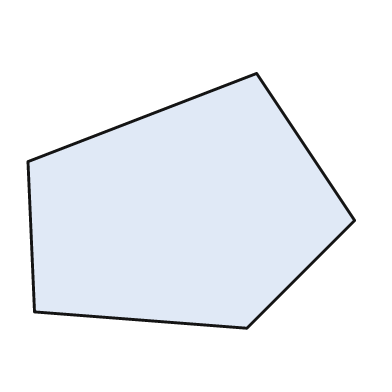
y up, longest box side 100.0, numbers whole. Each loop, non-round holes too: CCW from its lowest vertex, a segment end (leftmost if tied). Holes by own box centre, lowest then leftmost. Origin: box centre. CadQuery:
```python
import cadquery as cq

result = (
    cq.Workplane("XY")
    .moveTo(17.0, -39.0)
    .lineTo(50.0, -6.0)
    .lineTo(20.0, 39.0)
    .lineTo(-50.0, 12.0)
    .lineTo(-48.0, -34.0)
    .close()
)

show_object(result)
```